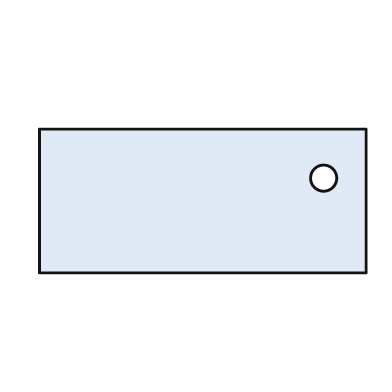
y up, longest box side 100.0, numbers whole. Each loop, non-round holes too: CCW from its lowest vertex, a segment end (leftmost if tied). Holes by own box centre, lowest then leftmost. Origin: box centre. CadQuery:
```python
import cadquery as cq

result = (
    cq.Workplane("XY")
    .moveTo(-50.0, -22.0)
    .lineTo(50.0, -22.0)
    .lineTo(50.0, 22.0)
    .lineTo(-50.0, 22.0)
    .close()
    .moveTo(37.0, 7.0)
    .circle(4.0)
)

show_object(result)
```